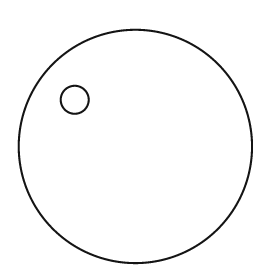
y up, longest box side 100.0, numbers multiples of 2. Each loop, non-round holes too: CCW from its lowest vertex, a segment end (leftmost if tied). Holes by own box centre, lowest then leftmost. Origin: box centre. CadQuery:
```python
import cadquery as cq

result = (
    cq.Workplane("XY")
    .moveTo(0.0, 0.0)
    .circle(50.0)
    .moveTo(-26.0, 20.0)
    .circle(6.0)
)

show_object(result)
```